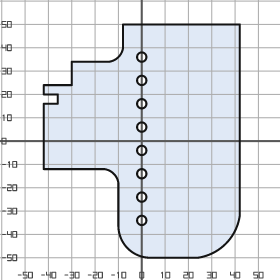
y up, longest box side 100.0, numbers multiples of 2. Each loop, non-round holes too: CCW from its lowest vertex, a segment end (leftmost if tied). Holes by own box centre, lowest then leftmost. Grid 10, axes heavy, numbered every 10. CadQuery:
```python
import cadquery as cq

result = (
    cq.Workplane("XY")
    .moveTo(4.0, -50.0)
    .lineTo(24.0, -50.0)
    .threePointArc((36.0, -44.0), (42.0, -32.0))
    .lineTo(42.0, 50.0)
    .lineTo(-8.0, 50.0)
    .lineTo(-8.0, 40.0)
    .threePointArc((-10.0, 36.0), (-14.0, 34.0))
    .lineTo(-30.0, 34.0)
    .lineTo(-30.0, 24.0)
    .lineTo(-42.0, 24.0)
    .lineTo(-42.0, 20.0)
    .lineTo(-36.0, 20.0)
    .lineTo(-36.0, 16.0)
    .lineTo(-42.0, 16.0)
    .lineTo(-42.0, -12.0)
    .lineTo(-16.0, -12.0)
    .threePointArc((-12.0, -14.0), (-10.0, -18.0))
    .lineTo(-10.0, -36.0)
    .threePointArc((-6.0, -46.0), (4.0, -50.0))
    .close()
    .moveTo(0.0, -34.0)
    .circle(2.0)
    .moveTo(0.0, -24.0)
    .circle(2.0)
    .moveTo(0.0, -14.0)
    .circle(2.0)
    .moveTo(0.0, -4.0)
    .circle(2.0)
    .moveTo(0.0, 6.0)
    .circle(2.0)
    .moveTo(0.0, 16.0)
    .circle(2.0)
    .moveTo(0.0, 26.0)
    .circle(2.0)
    .moveTo(0.0, 36.0)
    .circle(2.0)
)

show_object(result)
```